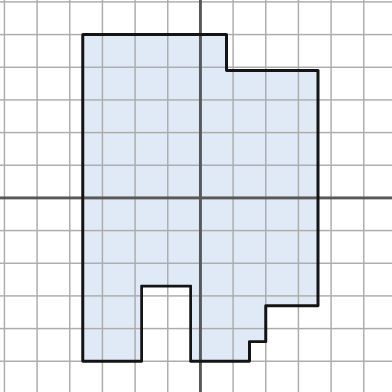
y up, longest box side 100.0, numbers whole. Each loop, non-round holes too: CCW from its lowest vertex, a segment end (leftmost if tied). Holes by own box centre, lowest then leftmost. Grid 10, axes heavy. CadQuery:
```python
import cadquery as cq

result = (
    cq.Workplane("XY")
    .moveTo(-36.0, -50.0)
    .lineTo(-18.0, -50.0)
    .lineTo(-18.0, -27.0)
    .lineTo(-3.0, -27.0)
    .lineTo(-3.0, -50.0)
    .lineTo(15.0, -50.0)
    .lineTo(15.0, -44.0)
    .lineTo(20.0, -44.0)
    .lineTo(20.0, -33.0)
    .lineTo(36.0, -33.0)
    .lineTo(36.0, 39.0)
    .lineTo(8.0, 39.0)
    .lineTo(8.0, 50.0)
    .lineTo(-36.0, 50.0)
    .close()
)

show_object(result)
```